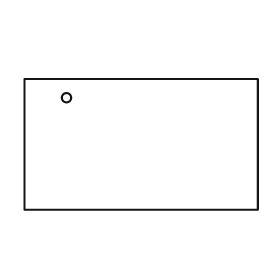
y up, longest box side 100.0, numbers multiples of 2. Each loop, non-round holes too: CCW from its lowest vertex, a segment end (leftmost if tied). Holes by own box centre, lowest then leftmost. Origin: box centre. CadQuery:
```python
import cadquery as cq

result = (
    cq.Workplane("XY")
    .moveTo(-50.0, -28.0)
    .lineTo(50.0, -28.0)
    .lineTo(50.0, 28.0)
    .lineTo(-50.0, 28.0)
    .close()
    .moveTo(-32.0, 20.0)
    .circle(2.0)
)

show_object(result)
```